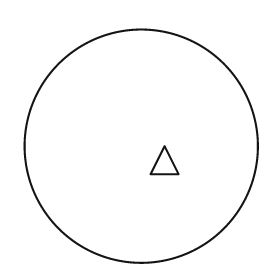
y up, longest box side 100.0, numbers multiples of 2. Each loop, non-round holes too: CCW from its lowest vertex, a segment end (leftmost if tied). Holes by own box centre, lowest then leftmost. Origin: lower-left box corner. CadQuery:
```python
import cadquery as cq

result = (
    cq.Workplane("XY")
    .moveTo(50.0, 50.0)
    .circle(50.0)
    .moveTo(54.0, 38.0)
    .lineTo(66.0, 38.0)
    .lineTo(60.0, 50.0)
    .close()
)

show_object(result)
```